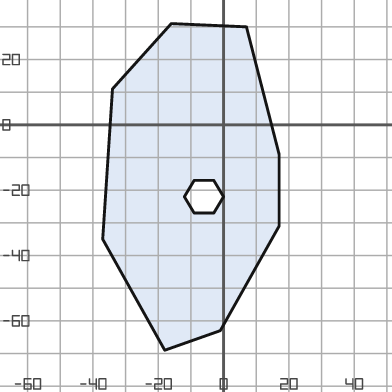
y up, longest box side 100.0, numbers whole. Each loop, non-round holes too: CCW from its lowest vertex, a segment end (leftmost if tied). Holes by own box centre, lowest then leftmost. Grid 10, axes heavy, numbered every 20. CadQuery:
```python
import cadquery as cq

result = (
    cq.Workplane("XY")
    .moveTo(-18.0, -69.0)
    .lineTo(-1.0, -63.0)
    .lineTo(17.0, -31.0)
    .lineTo(17.0, -9.0)
    .lineTo(7.0, 30.0)
    .lineTo(-16.0, 31.0)
    .lineTo(-34.0, 11.0)
    .lineTo(-37.0, -35.0)
    .close()
    .moveTo(-9.0, -27.0)
    .lineTo(-3.0, -27.0)
    .lineTo(0.0, -22.0)
    .lineTo(-3.0, -17.0)
    .lineTo(-9.0, -17.0)
    .lineTo(-12.0, -22.0)
    .close()
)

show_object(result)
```